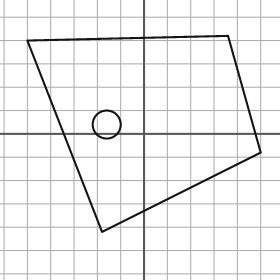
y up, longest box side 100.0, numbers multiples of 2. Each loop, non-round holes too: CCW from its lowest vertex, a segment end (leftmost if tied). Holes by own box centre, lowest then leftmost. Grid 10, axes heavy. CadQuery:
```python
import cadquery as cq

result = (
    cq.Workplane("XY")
    .moveTo(-18.0, -42.0)
    .lineTo(50.0, -8.0)
    .lineTo(36.0, 42.0)
    .lineTo(-50.0, 40.0)
    .close()
    .moveTo(-16.0, 4.0)
    .circle(6.0)
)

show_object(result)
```